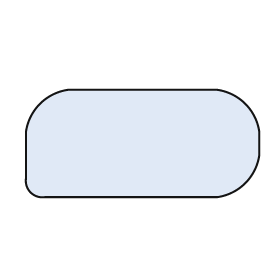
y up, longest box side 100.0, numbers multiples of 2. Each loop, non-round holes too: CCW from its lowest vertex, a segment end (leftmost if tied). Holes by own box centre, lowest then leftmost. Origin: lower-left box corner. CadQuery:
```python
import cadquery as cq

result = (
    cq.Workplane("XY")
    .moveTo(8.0, 0.0)
    .lineTo(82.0, 0.0)
    .threePointArc((94.0, 6.0), (100.0, 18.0))
    .lineTo(100.0, 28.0)
    .threePointArc((94.0, 40.0), (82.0, 46.0))
    .lineTo(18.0, 46.0)
    .threePointArc((6.0, 40.0), (0.0, 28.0))
    .lineTo(0.0, 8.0)
    .threePointArc((2.0, 2.0), (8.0, 0.0))
    .close()
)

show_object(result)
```